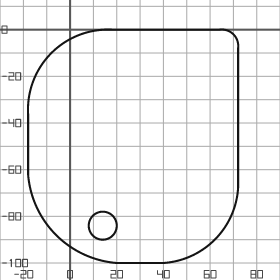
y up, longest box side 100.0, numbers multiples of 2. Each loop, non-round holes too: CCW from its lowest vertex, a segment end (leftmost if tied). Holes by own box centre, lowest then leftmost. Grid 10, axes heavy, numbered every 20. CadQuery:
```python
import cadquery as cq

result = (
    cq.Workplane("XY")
    .moveTo(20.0, -100.0)
    .lineTo(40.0, -100.0)
    .threePointArc((62.0, -90.0), (72.0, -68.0))
    .lineTo(72.0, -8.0)
    .threePointArc((70.0, -2.0), (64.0, 0.0))
    .lineTo(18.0, 0.0)
    .threePointArc((-8.0, -10.0), (-18.0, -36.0))
    .lineTo(-18.0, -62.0)
    .threePointArc((-6.0, -88.0), (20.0, -100.0))
    .close()
    .moveTo(14.0, -84.0)
    .circle(6.0)
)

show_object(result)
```